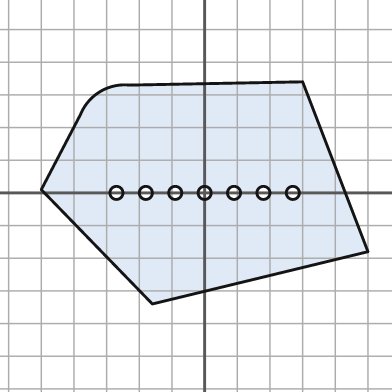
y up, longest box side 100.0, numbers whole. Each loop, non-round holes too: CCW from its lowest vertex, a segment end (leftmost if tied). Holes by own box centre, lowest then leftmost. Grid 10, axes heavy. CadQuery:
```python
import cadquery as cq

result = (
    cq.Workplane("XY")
    .moveTo(-16.0, -34.0)
    .lineTo(50.0, -18.0)
    .lineTo(30.0, 34.0)
    .lineTo(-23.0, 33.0)
    .threePointArc((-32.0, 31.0), (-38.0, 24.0))
    .lineTo(-50.0, 1.0)
    .close()
    .moveTo(-27.0, 0.0)
    .circle(2.0)
    .moveTo(-18.0, 0.0)
    .circle(2.0)
    .moveTo(-9.0, 0.0)
    .circle(2.0)
    .moveTo(0.0, 0.0)
    .circle(2.0)
    .moveTo(9.0, 0.0)
    .circle(2.0)
    .moveTo(18.0, 0.0)
    .circle(2.0)
    .moveTo(27.0, 0.0)
    .circle(2.0)
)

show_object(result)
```